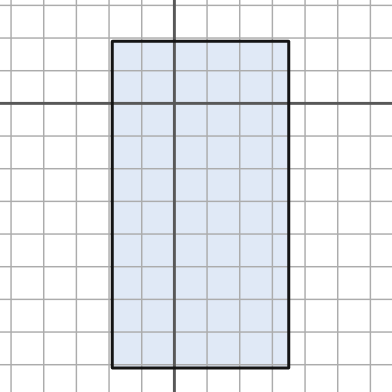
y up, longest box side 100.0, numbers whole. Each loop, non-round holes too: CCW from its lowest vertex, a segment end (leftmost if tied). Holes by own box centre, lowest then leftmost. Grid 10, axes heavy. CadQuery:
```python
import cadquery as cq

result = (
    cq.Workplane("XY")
    .moveTo(-19.0, -81.0)
    .lineTo(35.0, -81.0)
    .lineTo(35.0, 19.0)
    .lineTo(-19.0, 19.0)
    .close()
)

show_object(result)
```